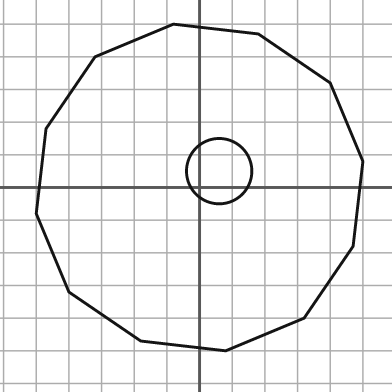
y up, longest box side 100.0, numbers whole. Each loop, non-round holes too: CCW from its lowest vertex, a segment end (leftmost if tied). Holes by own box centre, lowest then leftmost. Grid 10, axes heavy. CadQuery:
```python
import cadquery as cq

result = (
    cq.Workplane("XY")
    .moveTo(8.0, -50.0)
    .lineTo(32.0, -40.0)
    .lineTo(47.0, -18.0)
    .lineTo(50.0, 8.0)
    .lineTo(40.0, 32.0)
    .lineTo(18.0, 47.0)
    .lineTo(-8.0, 50.0)
    .lineTo(-32.0, 40.0)
    .lineTo(-47.0, 18.0)
    .lineTo(-50.0, -8.0)
    .lineTo(-40.0, -32.0)
    .lineTo(-18.0, -47.0)
    .close()
    .moveTo(6.0, 5.0)
    .circle(10.0)
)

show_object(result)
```